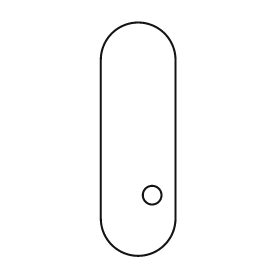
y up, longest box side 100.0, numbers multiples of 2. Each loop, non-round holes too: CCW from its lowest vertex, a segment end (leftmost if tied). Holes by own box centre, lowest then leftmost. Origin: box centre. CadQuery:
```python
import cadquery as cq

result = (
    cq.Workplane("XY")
    .moveTo(-16.0, -34.0)
    .threePointArc((0.0, -50.0), (16.0, -34.0))
    .lineTo(16.0, 34.0)
    .threePointArc((0.0, 50.0), (-16.0, 34.0))
    .close()
    .moveTo(6.0, -24.0)
    .circle(4.0)
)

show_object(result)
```